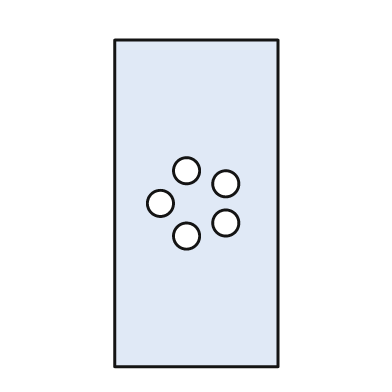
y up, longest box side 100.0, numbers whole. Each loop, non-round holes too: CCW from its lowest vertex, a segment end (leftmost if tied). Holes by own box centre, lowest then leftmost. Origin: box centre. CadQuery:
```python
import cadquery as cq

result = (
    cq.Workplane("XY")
    .moveTo(-25.0, -50.0)
    .lineTo(25.0, -50.0)
    .lineTo(25.0, 50.0)
    .lineTo(-25.0, 50.0)
    .close()
    .moveTo(-3.0, -10.0)
    .circle(4.0)
    .moveTo(9.0, -6.0)
    .circle(4.0)
    .moveTo(-11.0, 0.0)
    .circle(4.0)
    .moveTo(9.0, 6.0)
    .circle(4.0)
    .moveTo(-3.0, 10.0)
    .circle(4.0)
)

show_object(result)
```